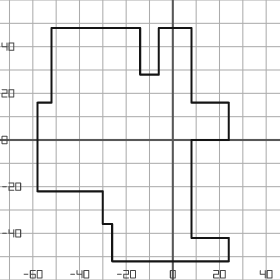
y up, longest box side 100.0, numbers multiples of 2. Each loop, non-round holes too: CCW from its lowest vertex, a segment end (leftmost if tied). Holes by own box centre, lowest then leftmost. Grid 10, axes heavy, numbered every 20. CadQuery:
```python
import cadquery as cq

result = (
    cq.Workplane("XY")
    .moveTo(-26.0, -52.0)
    .lineTo(24.0, -52.0)
    .lineTo(24.0, -42.0)
    .lineTo(8.0, -42.0)
    .lineTo(8.0, 0.0)
    .lineTo(24.0, 0.0)
    .lineTo(24.0, 16.0)
    .lineTo(8.0, 16.0)
    .lineTo(8.0, 48.0)
    .lineTo(-6.0, 48.0)
    .lineTo(-6.0, 28.0)
    .lineTo(-14.0, 28.0)
    .lineTo(-14.0, 48.0)
    .lineTo(-52.0, 48.0)
    .lineTo(-52.0, 16.0)
    .lineTo(-58.0, 16.0)
    .lineTo(-58.0, -22.0)
    .lineTo(-30.0, -22.0)
    .lineTo(-30.0, -36.0)
    .lineTo(-26.0, -36.0)
    .close()
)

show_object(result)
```